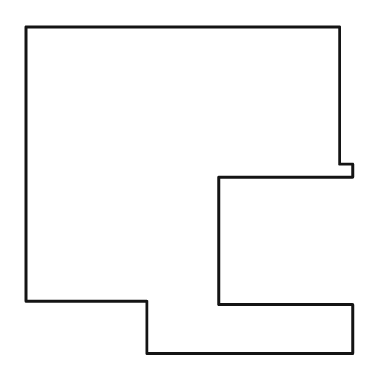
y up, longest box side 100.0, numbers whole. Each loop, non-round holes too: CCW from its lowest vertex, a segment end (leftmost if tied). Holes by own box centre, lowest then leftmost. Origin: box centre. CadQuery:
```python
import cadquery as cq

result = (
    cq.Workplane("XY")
    .moveTo(-13.0, -50.0)
    .lineTo(50.0, -50.0)
    .lineTo(50.0, -35.0)
    .lineTo(9.0, -35.0)
    .lineTo(9.0, 4.0)
    .lineTo(50.0, 4.0)
    .lineTo(50.0, 8.0)
    .lineTo(46.0, 8.0)
    .lineTo(46.0, 50.0)
    .lineTo(-50.0, 50.0)
    .lineTo(-50.0, -34.0)
    .lineTo(-13.0, -34.0)
    .close()
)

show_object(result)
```